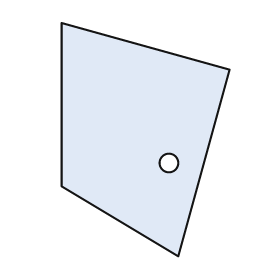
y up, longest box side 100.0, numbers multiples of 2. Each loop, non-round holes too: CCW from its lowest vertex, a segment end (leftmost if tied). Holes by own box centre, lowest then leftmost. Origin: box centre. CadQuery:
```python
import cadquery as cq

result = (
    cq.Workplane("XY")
    .moveTo(14.0, -50.0)
    .lineTo(36.0, 30.0)
    .lineTo(-36.0, 50.0)
    .lineTo(-36.0, -20.0)
    .close()
    .moveTo(10.0, -10.0)
    .circle(4.0)
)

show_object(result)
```